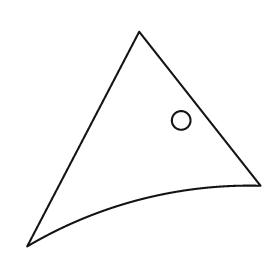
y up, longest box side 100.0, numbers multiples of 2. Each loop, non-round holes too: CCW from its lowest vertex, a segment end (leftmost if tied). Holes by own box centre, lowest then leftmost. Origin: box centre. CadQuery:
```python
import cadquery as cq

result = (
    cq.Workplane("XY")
    .moveTo(-50.0, -46.0)
    .threePointArc((-2.0, -26.0), (50.0, -20.0))
    .lineTo(-2.0, 46.0)
    .close()
    .moveTo(16.0, 8.0)
    .circle(4.0)
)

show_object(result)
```